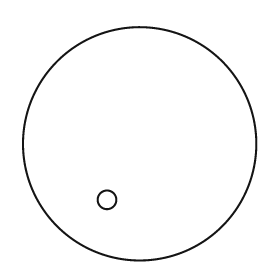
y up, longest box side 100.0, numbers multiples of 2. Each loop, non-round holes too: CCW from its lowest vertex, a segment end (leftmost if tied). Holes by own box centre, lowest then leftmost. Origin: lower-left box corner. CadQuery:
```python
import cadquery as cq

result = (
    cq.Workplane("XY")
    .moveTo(50.0, 50.0)
    .circle(50.0)
    .moveTo(36.0, 26.0)
    .circle(4.0)
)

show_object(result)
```